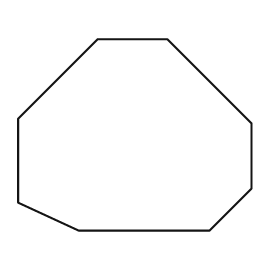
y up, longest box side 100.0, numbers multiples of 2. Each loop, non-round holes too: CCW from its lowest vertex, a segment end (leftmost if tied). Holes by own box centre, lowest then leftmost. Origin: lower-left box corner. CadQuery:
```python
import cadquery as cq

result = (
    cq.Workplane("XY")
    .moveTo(26.0, 0.0)
    .lineTo(82.0, 0.0)
    .lineTo(100.0, 18.0)
    .lineTo(100.0, 46.0)
    .lineTo(64.0, 82.0)
    .lineTo(34.0, 82.0)
    .lineTo(0.0, 48.0)
    .lineTo(0.0, 12.0)
    .close()
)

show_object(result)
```